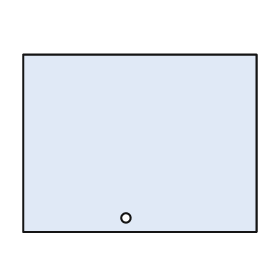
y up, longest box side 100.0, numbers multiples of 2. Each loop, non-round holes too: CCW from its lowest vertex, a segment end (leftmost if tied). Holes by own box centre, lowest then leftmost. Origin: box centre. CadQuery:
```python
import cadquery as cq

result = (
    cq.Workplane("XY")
    .moveTo(-50.0, -38.0)
    .lineTo(50.0, -38.0)
    .lineTo(50.0, 38.0)
    .lineTo(-50.0, 38.0)
    .close()
    .moveTo(-6.0, -32.0)
    .circle(2.0)
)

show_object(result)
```